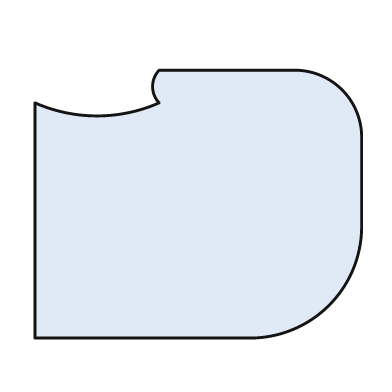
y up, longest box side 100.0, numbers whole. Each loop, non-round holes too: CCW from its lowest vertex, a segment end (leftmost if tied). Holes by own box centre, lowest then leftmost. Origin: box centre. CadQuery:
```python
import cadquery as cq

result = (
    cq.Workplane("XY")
    .moveTo(-50.0, -41.0)
    .lineTo(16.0, -41.0)
    .threePointArc((40.0, -31.0), (50.0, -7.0))
    .lineTo(50.0, 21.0)
    .threePointArc((44.0, 35.0), (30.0, 41.0))
    .lineTo(-12.0, 41.0)
    .threePointArc((-14.0, 36.0), (-12.0, 31.0))
    .threePointArc((-31.0, 27.0), (-50.0, 31.0))
    .close()
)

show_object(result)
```